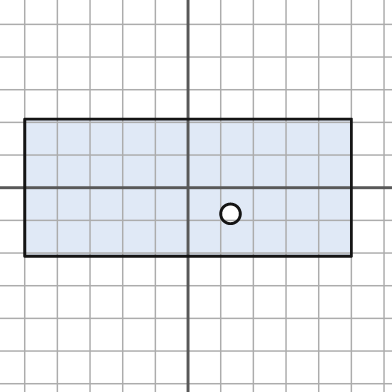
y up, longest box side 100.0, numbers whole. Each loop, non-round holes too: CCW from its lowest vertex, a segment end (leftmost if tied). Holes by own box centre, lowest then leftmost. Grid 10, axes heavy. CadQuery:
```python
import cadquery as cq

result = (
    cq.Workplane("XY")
    .moveTo(-50.0, -21.0)
    .lineTo(50.0, -21.0)
    .lineTo(50.0, 21.0)
    .lineTo(-50.0, 21.0)
    .close()
    .moveTo(13.0, -8.0)
    .circle(3.0)
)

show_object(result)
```